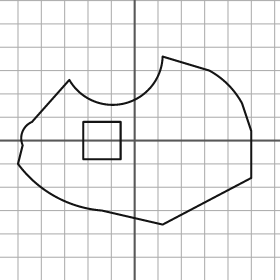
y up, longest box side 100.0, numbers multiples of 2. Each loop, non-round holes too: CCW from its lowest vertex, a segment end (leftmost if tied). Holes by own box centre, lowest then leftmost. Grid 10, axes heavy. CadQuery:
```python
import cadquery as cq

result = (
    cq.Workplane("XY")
    .moveTo(12.0, -36.0)
    .lineTo(50.0, -16.0)
    .lineTo(50.0, 4.0)
    .lineTo(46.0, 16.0)
    .threePointArc((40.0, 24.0), (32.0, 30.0))
    .lineTo(12.0, 36.0)
    .threePointArc((-4.0, 16.0), (-28.0, 26.0))
    .lineTo(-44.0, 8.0)
    .threePointArc((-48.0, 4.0), (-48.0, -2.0))
    .lineTo(-50.0, -10.0)
    .threePointArc((-34.0, -24.0), (-14.0, -30.0))
    .close()
    .moveTo(-22.0, -8.0)
    .lineTo(-6.0, -8.0)
    .lineTo(-6.0, 8.0)
    .lineTo(-22.0, 8.0)
    .close()
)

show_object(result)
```